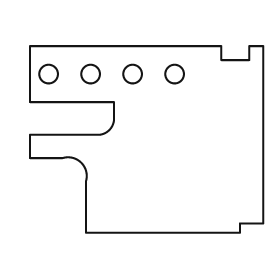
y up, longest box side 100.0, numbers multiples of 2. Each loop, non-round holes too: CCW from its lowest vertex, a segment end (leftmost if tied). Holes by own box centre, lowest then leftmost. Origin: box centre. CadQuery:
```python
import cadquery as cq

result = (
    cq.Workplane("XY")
    .moveTo(-26.0, -40.0)
    .lineTo(40.0, -40.0)
    .lineTo(40.0, -36.0)
    .lineTo(50.0, -36.0)
    .lineTo(50.0, 40.0)
    .lineTo(44.0, 40.0)
    .lineTo(44.0, 34.0)
    .lineTo(32.0, 34.0)
    .lineTo(32.0, 40.0)
    .lineTo(-50.0, 40.0)
    .lineTo(-50.0, 16.0)
    .lineTo(-14.0, 16.0)
    .lineTo(-14.0, 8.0)
    .threePointArc((-16.0, 4.0), (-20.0, 2.0))
    .lineTo(-50.0, 2.0)
    .lineTo(-50.0, -8.0)
    .lineTo(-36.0, -8.0)
    .threePointArc((-28.0, -10.0), (-26.0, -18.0))
    .close()
    .moveTo(-42.0, 28.0)
    .circle(4.0)
    .moveTo(-24.0, 28.0)
    .circle(4.0)
    .moveTo(-6.0, 28.0)
    .circle(4.0)
    .moveTo(12.0, 28.0)
    .circle(4.0)
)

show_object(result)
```